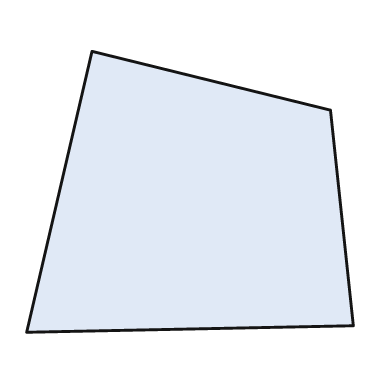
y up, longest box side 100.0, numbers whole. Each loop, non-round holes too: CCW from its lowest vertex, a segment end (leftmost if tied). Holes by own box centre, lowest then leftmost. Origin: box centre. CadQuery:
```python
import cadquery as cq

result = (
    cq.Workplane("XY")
    .moveTo(-50.0, -43.0)
    .lineTo(50.0, -41.0)
    .lineTo(43.0, 25.0)
    .lineTo(-30.0, 43.0)
    .close()
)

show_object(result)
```